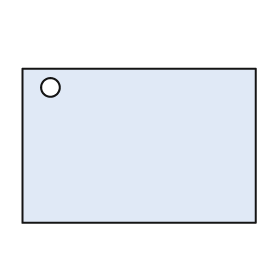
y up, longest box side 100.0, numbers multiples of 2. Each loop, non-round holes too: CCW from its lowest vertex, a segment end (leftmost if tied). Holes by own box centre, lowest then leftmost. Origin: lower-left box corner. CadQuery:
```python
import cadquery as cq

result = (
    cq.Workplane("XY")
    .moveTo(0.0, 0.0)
    .lineTo(100.0, 0.0)
    .lineTo(100.0, 66.0)
    .lineTo(0.0, 66.0)
    .close()
    .moveTo(12.0, 58.0)
    .circle(4.0)
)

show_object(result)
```